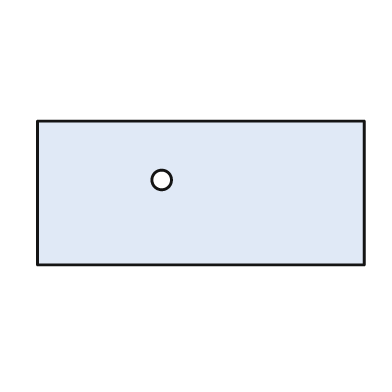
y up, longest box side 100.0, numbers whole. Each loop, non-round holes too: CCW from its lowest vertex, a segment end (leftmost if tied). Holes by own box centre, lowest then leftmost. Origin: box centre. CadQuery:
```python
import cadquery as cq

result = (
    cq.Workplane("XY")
    .moveTo(-50.0, -22.0)
    .lineTo(50.0, -22.0)
    .lineTo(50.0, 22.0)
    .lineTo(-50.0, 22.0)
    .close()
    .moveTo(-12.0, 4.0)
    .circle(3.0)
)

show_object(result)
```